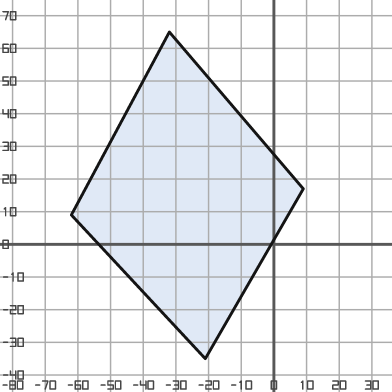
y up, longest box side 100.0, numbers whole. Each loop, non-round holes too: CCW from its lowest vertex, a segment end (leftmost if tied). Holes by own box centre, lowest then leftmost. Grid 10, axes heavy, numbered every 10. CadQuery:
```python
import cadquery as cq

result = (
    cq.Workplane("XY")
    .moveTo(-21.0, -35.0)
    .lineTo(9.0, 17.0)
    .lineTo(-32.0, 65.0)
    .lineTo(-62.0, 9.0)
    .close()
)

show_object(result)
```